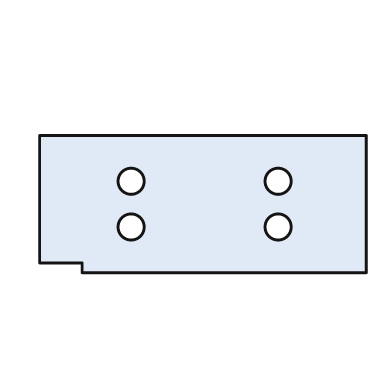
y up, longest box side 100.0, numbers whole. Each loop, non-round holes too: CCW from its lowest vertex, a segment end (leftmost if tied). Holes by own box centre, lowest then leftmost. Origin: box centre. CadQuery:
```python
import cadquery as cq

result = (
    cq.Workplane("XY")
    .moveTo(-37.0, -21.0)
    .lineTo(50.0, -21.0)
    .lineTo(50.0, 21.0)
    .lineTo(-50.0, 21.0)
    .lineTo(-50.0, -18.0)
    .lineTo(-37.0, -18.0)
    .close()
    .moveTo(-22.0, -7.0)
    .circle(4.0)
    .moveTo(23.0, -7.0)
    .circle(4.0)
    .moveTo(-22.0, 7.0)
    .circle(4.0)
    .moveTo(23.0, 7.0)
    .circle(4.0)
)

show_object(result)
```